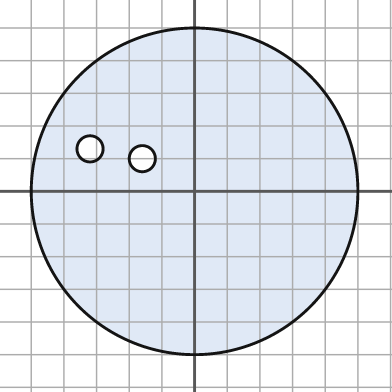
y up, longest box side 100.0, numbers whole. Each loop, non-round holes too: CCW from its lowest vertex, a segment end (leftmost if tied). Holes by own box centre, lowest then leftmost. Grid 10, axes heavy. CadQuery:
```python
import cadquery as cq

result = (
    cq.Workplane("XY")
    .moveTo(0.0, 0.0)
    .circle(50.0)
    .moveTo(-16.0, 10.0)
    .circle(4.0)
    .moveTo(-32.0, 13.0)
    .circle(4.0)
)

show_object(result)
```